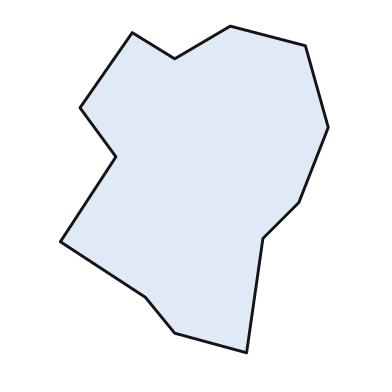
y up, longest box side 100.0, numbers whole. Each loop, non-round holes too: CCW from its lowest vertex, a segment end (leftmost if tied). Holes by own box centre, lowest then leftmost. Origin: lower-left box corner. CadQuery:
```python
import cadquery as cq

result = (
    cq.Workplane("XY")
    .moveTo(57.0, 0.0)
    .lineTo(62.0, 35.0)
    .lineTo(73.0, 46.0)
    .lineTo(82.0, 69.0)
    .lineTo(75.0, 94.0)
    .lineTo(52.0, 100.0)
    .lineTo(35.0, 90.0)
    .lineTo(22.0, 98.0)
    .lineTo(6.0, 75.0)
    .lineTo(17.0, 60.0)
    .lineTo(0.0, 34.0)
    .lineTo(26.0, 17.0)
    .lineTo(35.0, 6.0)
    .close()
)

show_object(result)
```